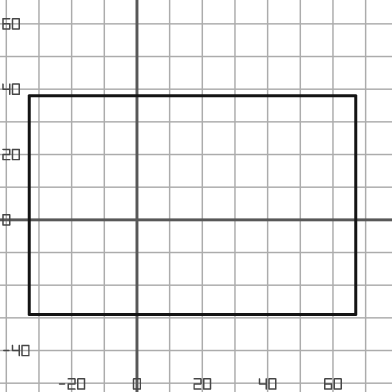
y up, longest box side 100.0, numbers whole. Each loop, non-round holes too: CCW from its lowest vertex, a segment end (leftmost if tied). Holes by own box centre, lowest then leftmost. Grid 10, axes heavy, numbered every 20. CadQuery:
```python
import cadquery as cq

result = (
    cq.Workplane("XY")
    .moveTo(-33.0, -29.0)
    .lineTo(67.0, -29.0)
    .lineTo(67.0, 38.0)
    .lineTo(-33.0, 38.0)
    .close()
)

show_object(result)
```